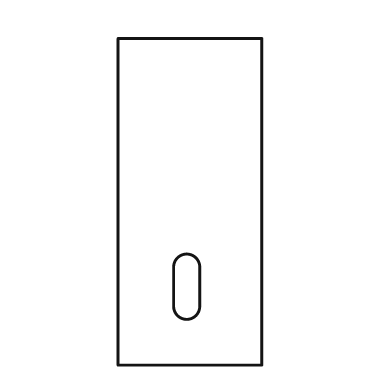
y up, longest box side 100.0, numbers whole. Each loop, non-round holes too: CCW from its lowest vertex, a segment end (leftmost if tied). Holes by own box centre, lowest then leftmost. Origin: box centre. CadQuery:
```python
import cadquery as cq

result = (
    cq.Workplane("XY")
    .moveTo(-22.0, -50.0)
    .lineTo(22.0, -50.0)
    .lineTo(22.0, 50.0)
    .lineTo(-22.0, 50.0)
    .close()
    .moveTo(-5.0, -32.0)
    .threePointArc((-1.0, -36.0), (3.0, -32.0))
    .lineTo(3.0, -20.0)
    .threePointArc((-1.0, -16.0), (-5.0, -20.0))
    .close()
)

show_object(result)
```